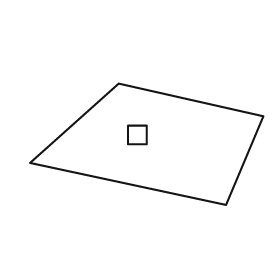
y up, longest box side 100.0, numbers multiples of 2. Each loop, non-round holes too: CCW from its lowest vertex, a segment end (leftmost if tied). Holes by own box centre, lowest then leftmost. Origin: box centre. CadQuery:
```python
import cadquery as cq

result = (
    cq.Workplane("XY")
    .moveTo(34.0, -26.0)
    .lineTo(50.0, 12.0)
    .lineTo(-12.0, 26.0)
    .lineTo(-50.0, -8.0)
    .close()
    .moveTo(-8.0, 0.0)
    .lineTo(0.0, 0.0)
    .lineTo(0.0, 8.0)
    .lineTo(-8.0, 8.0)
    .close()
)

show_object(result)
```